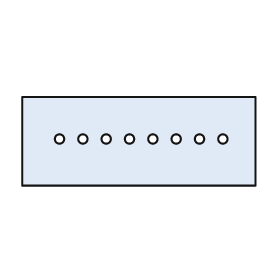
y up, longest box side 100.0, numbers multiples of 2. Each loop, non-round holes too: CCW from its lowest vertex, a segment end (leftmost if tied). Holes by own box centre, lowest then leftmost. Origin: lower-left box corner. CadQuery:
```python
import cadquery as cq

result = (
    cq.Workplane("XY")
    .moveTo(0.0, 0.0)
    .lineTo(100.0, 0.0)
    .lineTo(100.0, 38.0)
    .lineTo(0.0, 38.0)
    .close()
    .moveTo(16.0, 20.0)
    .circle(2.0)
    .moveTo(26.0, 20.0)
    .circle(2.0)
    .moveTo(36.0, 20.0)
    .circle(2.0)
    .moveTo(46.0, 20.0)
    .circle(2.0)
    .moveTo(56.0, 20.0)
    .circle(2.0)
    .moveTo(66.0, 20.0)
    .circle(2.0)
    .moveTo(76.0, 20.0)
    .circle(2.0)
    .moveTo(86.0, 20.0)
    .circle(2.0)
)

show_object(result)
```